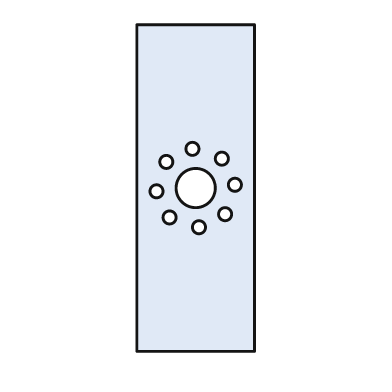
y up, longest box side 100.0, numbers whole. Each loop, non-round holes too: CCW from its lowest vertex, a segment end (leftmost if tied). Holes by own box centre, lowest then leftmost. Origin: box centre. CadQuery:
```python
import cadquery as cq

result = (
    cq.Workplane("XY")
    .moveTo(-18.0, -50.0)
    .lineTo(18.0, -50.0)
    .lineTo(18.0, 50.0)
    .lineTo(-18.0, 50.0)
    .close()
    .moveTo(1.0, -12.0)
    .circle(2.0)
    .moveTo(-8.0, -9.0)
    .circle(2.0)
    .moveTo(9.0, -8.0)
    .circle(2.0)
    .moveTo(-12.0, -1.0)
    .circle(2.0)
    .moveTo(0.0, 0.0)
    .circle(6.0)
    .moveTo(12.0, 1.0)
    .circle(2.0)
    .moveTo(-9.0, 8.0)
    .circle(2.0)
    .moveTo(8.0, 9.0)
    .circle(2.0)
    .moveTo(-1.0, 12.0)
    .circle(2.0)
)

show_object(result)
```